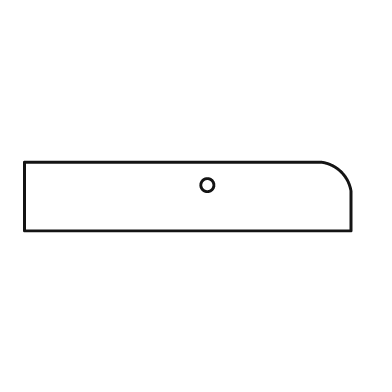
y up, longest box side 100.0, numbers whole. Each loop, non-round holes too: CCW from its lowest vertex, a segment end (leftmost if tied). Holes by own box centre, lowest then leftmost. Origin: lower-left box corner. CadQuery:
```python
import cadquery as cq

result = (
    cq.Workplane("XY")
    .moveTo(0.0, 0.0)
    .lineTo(100.0, 0.0)
    .lineTo(100.0, 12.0)
    .threePointArc((97.0, 18.0), (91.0, 21.0))
    .lineTo(0.0, 21.0)
    .close()
    .moveTo(56.0, 14.0)
    .circle(2.0)
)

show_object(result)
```